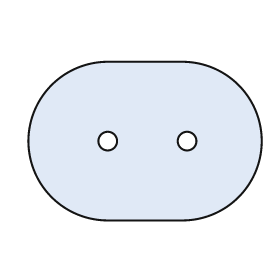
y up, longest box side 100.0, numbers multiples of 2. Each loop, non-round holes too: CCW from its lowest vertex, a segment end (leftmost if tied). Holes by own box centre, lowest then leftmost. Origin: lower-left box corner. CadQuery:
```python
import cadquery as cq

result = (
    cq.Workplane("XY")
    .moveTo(34.0, 0.0)
    .lineTo(66.0, 0.0)
    .threePointArc((100.0, 34.0), (66.0, 68.0))
    .lineTo(34.0, 68.0)
    .threePointArc((0.0, 34.0), (34.0, 0.0))
    .close()
    .moveTo(34.0, 34.0)
    .circle(4.0)
    .moveTo(68.0, 34.0)
    .circle(4.0)
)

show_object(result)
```